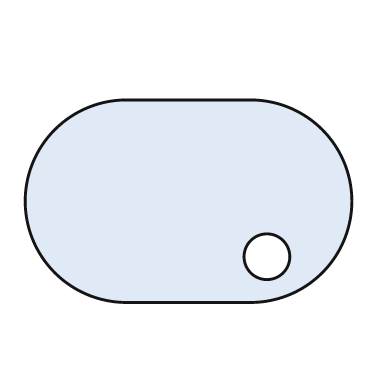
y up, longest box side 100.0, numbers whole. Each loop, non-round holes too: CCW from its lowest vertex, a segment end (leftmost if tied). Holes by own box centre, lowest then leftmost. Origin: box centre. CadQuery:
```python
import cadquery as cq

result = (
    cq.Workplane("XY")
    .moveTo(-19.0, -31.0)
    .lineTo(19.0, -31.0)
    .threePointArc((50.0, 0.0), (19.0, 31.0))
    .lineTo(-19.0, 31.0)
    .threePointArc((-50.0, 0.0), (-19.0, -31.0))
    .close()
    .moveTo(24.0, -17.0)
    .circle(7.0)
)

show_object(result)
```